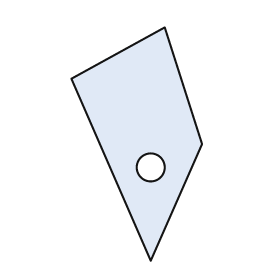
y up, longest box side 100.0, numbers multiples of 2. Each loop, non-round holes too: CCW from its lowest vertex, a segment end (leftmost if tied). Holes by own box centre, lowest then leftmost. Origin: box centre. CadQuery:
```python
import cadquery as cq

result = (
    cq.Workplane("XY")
    .moveTo(6.0, -50.0)
    .lineTo(28.0, 0.0)
    .lineTo(12.0, 50.0)
    .lineTo(-28.0, 28.0)
    .close()
    .moveTo(6.0, -10.0)
    .circle(6.0)
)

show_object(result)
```